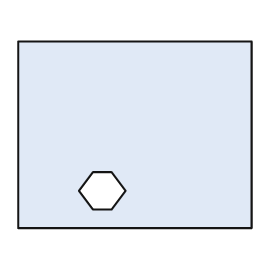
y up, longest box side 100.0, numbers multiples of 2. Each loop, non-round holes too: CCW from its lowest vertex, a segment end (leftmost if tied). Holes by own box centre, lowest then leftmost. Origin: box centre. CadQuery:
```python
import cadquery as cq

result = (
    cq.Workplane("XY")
    .moveTo(-50.0, -40.0)
    .lineTo(50.0, -40.0)
    .lineTo(50.0, 40.0)
    .lineTo(-50.0, 40.0)
    .close()
    .moveTo(-18.0, -32.0)
    .lineTo(-10.0, -32.0)
    .lineTo(-4.0, -24.0)
    .lineTo(-10.0, -16.0)
    .lineTo(-18.0, -16.0)
    .lineTo(-24.0, -24.0)
    .close()
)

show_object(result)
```